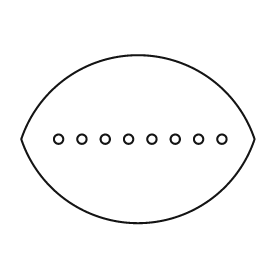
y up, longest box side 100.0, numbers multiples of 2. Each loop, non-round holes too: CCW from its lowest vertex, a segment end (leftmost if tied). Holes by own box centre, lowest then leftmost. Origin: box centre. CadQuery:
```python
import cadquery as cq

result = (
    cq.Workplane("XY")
    .moveTo(-50.0, 0.0)
    .threePointArc((0.0, -36.0), (50.0, 0.0))
    .threePointArc((0.0, 36.0), (-50.0, 0.0))
    .close()
    .moveTo(-34.0, 0.0)
    .circle(2.0)
    .moveTo(-24.0, 0.0)
    .circle(2.0)
    .moveTo(-14.0, 0.0)
    .circle(2.0)
    .moveTo(-4.0, 0.0)
    .circle(2.0)
    .moveTo(6.0, 0.0)
    .circle(2.0)
    .moveTo(16.0, 0.0)
    .circle(2.0)
    .moveTo(26.0, 0.0)
    .circle(2.0)
    .moveTo(36.0, 0.0)
    .circle(2.0)
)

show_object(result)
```